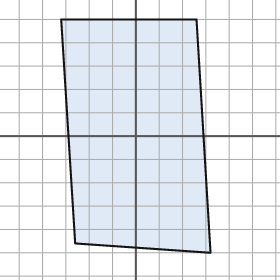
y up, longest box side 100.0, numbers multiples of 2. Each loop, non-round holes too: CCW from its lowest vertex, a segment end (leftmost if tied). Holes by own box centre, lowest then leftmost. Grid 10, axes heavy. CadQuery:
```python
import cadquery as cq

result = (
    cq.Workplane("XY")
    .moveTo(32.0, -50.0)
    .lineTo(26.0, 50.0)
    .lineTo(-32.0, 50.0)
    .lineTo(-26.0, -46.0)
    .close()
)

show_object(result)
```